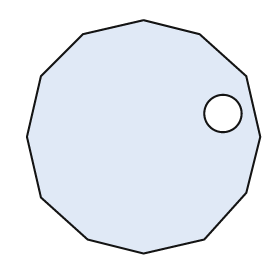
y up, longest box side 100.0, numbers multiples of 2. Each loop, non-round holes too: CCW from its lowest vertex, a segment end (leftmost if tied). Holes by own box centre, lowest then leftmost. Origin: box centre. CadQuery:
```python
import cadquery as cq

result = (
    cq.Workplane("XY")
    .moveTo(0.0, -50.0)
    .lineTo(26.0, -44.0)
    .lineTo(44.0, -24.0)
    .lineTo(50.0, 0.0)
    .lineTo(44.0, 26.0)
    .lineTo(24.0, 44.0)
    .lineTo(0.0, 50.0)
    .lineTo(-26.0, 44.0)
    .lineTo(-44.0, 26.0)
    .lineTo(-50.0, 0.0)
    .lineTo(-44.0, -26.0)
    .lineTo(-24.0, -44.0)
    .close()
    .moveTo(34.0, 10.0)
    .circle(8.0)
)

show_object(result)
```